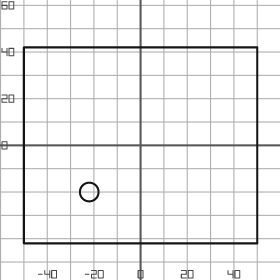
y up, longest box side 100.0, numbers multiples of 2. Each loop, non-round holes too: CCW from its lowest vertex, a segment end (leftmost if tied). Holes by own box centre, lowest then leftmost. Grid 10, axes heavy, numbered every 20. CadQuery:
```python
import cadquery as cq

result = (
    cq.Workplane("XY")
    .moveTo(-50.0, -42.0)
    .lineTo(50.0, -42.0)
    .lineTo(50.0, 42.0)
    .lineTo(-50.0, 42.0)
    .close()
    .moveTo(-22.0, -20.0)
    .circle(4.0)
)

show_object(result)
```